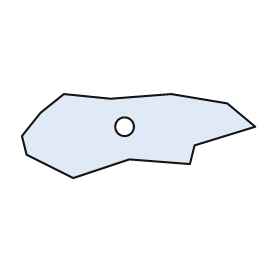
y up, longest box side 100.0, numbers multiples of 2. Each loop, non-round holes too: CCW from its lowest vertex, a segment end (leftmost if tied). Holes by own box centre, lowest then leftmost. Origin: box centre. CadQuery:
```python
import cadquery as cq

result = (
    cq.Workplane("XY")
    .moveTo(-28.0, -18.0)
    .lineTo(-4.0, -10.0)
    .lineTo(22.0, -12.0)
    .lineTo(24.0, -4.0)
    .lineTo(50.0, 4.0)
    .lineTo(38.0, 14.0)
    .lineTo(14.0, 18.0)
    .lineTo(-12.0, 16.0)
    .lineTo(-32.0, 18.0)
    .lineTo(-42.0, 10.0)
    .lineTo(-50.0, 0.0)
    .lineTo(-48.0, -8.0)
    .close()
    .moveTo(-6.0, 4.0)
    .circle(4.0)
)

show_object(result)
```